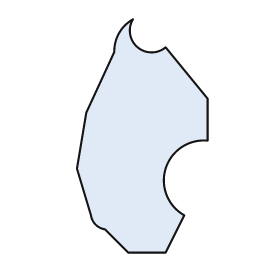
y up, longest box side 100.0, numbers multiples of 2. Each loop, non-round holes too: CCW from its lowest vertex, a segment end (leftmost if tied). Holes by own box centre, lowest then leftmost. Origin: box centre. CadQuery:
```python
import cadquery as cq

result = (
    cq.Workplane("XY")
    .moveTo(-6.0, -50.0)
    .lineTo(10.0, -50.0)
    .lineTo(18.0, -34.0)
    .threePointArc((10.0, -14.0), (28.0, -2.0))
    .lineTo(28.0, 16.0)
    .lineTo(10.0, 38.0)
    .threePointArc((-2.0, 38.0), (-4.0, 50.0))
    .threePointArc((-10.0, 44.0), (-12.0, 36.0))
    .lineTo(-24.0, 10.0)
    .lineTo(-28.0, -14.0)
    .lineTo(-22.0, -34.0)
    .threePointArc((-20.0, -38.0), (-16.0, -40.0))
    .close()
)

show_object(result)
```